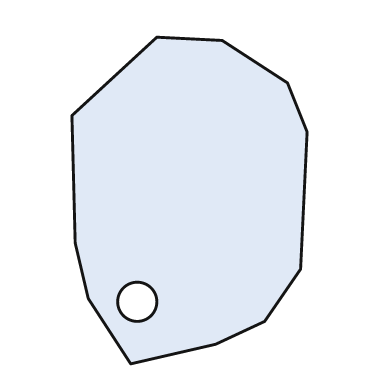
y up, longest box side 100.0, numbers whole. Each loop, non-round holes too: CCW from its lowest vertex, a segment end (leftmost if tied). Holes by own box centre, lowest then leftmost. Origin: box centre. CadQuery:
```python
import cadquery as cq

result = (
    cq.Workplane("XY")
    .moveTo(-18.0, -50.0)
    .lineTo(8.0, -44.0)
    .lineTo(23.0, -37.0)
    .lineTo(34.0, -21.0)
    .lineTo(36.0, 21.0)
    .lineTo(30.0, 36.0)
    .lineTo(10.0, 49.0)
    .lineTo(-10.0, 50.0)
    .lineTo(-36.0, 26.0)
    .lineTo(-35.0, -13.0)
    .lineTo(-31.0, -30.0)
    .close()
    .moveTo(-16.0, -31.0)
    .circle(6.0)
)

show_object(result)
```